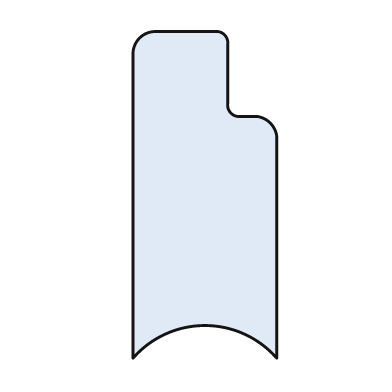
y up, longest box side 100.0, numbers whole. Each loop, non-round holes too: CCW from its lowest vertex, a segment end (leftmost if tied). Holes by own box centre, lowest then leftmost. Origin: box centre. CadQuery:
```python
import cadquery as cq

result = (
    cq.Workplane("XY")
    .moveTo(-22.0, -50.0)
    .threePointArc((0.0, -40.0), (22.0, -50.0))
    .lineTo(22.0, 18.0)
    .threePointArc((20.0, 22.0), (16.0, 24.0))
    .lineTo(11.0, 24.0)
    .threePointArc((8.0, 25.0), (7.0, 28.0))
    .lineTo(7.0, 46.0)
    .threePointArc((6.0, 49.0), (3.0, 50.0))
    .lineTo(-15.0, 50.0)
    .threePointArc((-20.0, 48.0), (-22.0, 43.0))
    .close()
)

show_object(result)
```